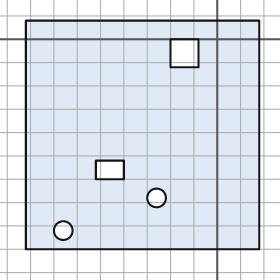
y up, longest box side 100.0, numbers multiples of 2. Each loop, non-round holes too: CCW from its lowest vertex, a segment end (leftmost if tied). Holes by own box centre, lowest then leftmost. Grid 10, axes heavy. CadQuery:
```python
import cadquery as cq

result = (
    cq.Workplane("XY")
    .moveTo(-82.0, -90.0)
    .lineTo(18.0, -90.0)
    .lineTo(18.0, 8.0)
    .lineTo(-82.0, 8.0)
    .close()
    .moveTo(-66.0, -82.0)
    .circle(4.0)
    .moveTo(-26.0, -68.0)
    .circle(4.0)
    .moveTo(-52.0, -60.0)
    .lineTo(-40.0, -60.0)
    .lineTo(-40.0, -52.0)
    .lineTo(-52.0, -52.0)
    .close()
    .moveTo(-20.0, -12.0)
    .lineTo(-8.0, -12.0)
    .lineTo(-8.0, 0.0)
    .lineTo(-20.0, 0.0)
    .close()
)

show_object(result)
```